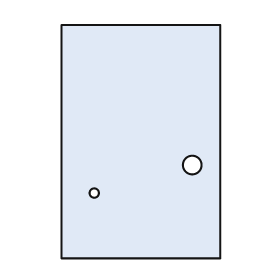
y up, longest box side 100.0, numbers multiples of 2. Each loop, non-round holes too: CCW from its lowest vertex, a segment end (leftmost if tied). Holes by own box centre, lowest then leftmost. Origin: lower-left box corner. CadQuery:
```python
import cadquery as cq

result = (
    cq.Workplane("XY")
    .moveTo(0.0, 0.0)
    .lineTo(68.0, 0.0)
    .lineTo(68.0, 100.0)
    .lineTo(0.0, 100.0)
    .close()
    .moveTo(14.0, 28.0)
    .circle(2.0)
    .moveTo(56.0, 40.0)
    .circle(4.0)
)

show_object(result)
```